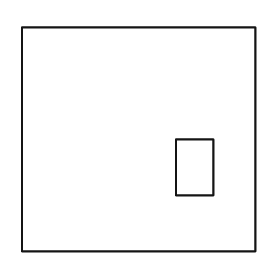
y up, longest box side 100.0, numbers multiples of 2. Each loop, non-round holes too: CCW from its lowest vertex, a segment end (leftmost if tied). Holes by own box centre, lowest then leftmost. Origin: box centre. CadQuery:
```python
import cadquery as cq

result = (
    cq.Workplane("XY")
    .moveTo(-50.0, -48.0)
    .lineTo(50.0, -48.0)
    .lineTo(50.0, 48.0)
    .lineTo(-50.0, 48.0)
    .close()
    .moveTo(16.0, -24.0)
    .lineTo(32.0, -24.0)
    .lineTo(32.0, 0.0)
    .lineTo(16.0, 0.0)
    .close()
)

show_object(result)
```